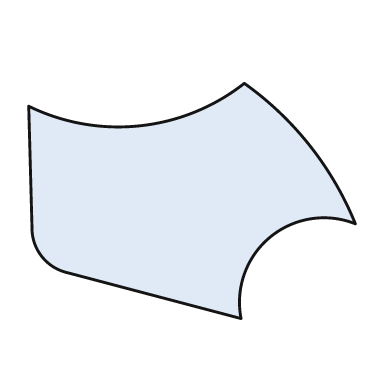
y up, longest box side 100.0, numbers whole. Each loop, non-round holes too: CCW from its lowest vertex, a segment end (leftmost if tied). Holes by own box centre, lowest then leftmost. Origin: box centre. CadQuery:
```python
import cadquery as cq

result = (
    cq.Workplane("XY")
    .moveTo(15.0, -36.0)
    .threePointArc((24.0, -11.0), (50.0, -7.0))
    .threePointArc((36.0, 17.0), (16.0, 36.0))
    .threePointArc((-16.0, 23.0), (-50.0, 29.0))
    .lineTo(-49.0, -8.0)
    .threePointArc((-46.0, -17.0), (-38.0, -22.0))
    .close()
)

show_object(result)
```